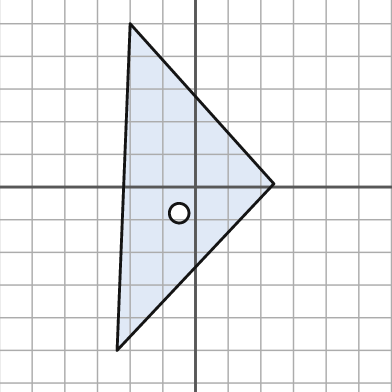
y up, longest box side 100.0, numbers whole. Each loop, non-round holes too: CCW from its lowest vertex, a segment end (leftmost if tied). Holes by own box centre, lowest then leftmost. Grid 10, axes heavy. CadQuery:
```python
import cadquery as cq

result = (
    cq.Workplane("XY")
    .moveTo(-24.0, -50.0)
    .lineTo(24.0, 1.0)
    .lineTo(-20.0, 50.0)
    .close()
    .moveTo(-5.0, -8.0)
    .circle(3.0)
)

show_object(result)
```